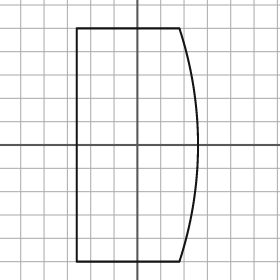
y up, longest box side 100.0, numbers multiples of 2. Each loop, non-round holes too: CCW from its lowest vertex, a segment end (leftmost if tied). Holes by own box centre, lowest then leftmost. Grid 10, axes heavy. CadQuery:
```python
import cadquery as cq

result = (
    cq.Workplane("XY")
    .moveTo(-26.0, -50.0)
    .lineTo(18.0, -50.0)
    .threePointArc((26.0, 0.0), (18.0, 50.0))
    .lineTo(-26.0, 50.0)
    .close()
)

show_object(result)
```